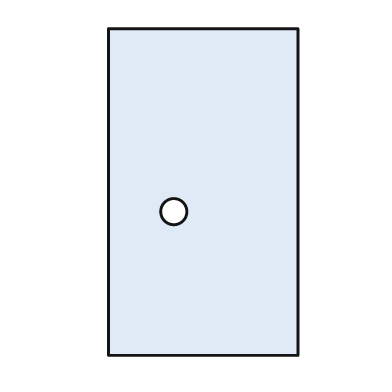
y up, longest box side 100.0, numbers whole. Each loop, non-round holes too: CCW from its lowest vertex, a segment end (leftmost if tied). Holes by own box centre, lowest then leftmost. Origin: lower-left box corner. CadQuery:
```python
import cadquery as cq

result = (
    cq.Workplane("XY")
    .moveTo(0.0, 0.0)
    .lineTo(58.0, 0.0)
    .lineTo(58.0, 100.0)
    .lineTo(0.0, 100.0)
    .close()
    .moveTo(20.0, 44.0)
    .circle(4.0)
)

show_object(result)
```